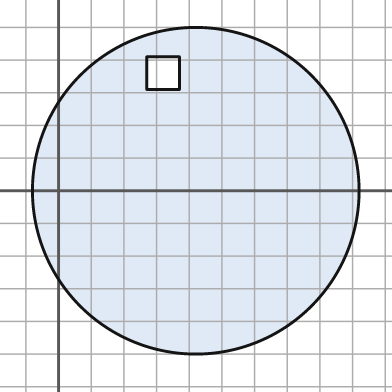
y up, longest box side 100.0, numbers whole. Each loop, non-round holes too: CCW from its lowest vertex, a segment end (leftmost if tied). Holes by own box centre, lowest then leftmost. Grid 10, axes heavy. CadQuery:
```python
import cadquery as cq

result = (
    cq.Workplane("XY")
    .moveTo(42.0, 0.0)
    .circle(50.0)
    .moveTo(27.0, 31.0)
    .lineTo(37.0, 31.0)
    .lineTo(37.0, 41.0)
    .lineTo(27.0, 41.0)
    .close()
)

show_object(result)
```